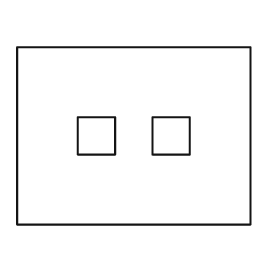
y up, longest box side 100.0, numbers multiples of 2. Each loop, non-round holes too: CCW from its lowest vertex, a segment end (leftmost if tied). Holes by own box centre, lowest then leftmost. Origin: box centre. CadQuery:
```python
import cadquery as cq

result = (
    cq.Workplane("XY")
    .moveTo(-50.0, -38.0)
    .lineTo(50.0, -38.0)
    .lineTo(50.0, 38.0)
    .lineTo(-50.0, 38.0)
    .close()
    .moveTo(-24.0, -8.0)
    .lineTo(-8.0, -8.0)
    .lineTo(-8.0, 8.0)
    .lineTo(-24.0, 8.0)
    .close()
    .moveTo(8.0, -8.0)
    .lineTo(24.0, -8.0)
    .lineTo(24.0, 8.0)
    .lineTo(8.0, 8.0)
    .close()
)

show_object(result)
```